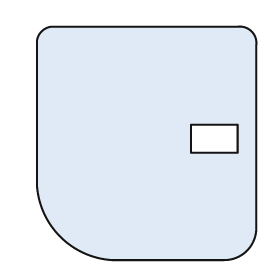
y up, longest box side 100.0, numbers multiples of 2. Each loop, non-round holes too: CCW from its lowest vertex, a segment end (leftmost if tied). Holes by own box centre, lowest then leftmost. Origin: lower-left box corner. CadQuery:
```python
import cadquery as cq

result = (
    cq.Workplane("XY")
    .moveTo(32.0, 0.0)
    .lineTo(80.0, 0.0)
    .threePointArc((90.0, 4.0), (94.0, 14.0))
    .lineTo(94.0, 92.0)
    .threePointArc((92.0, 98.0), (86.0, 100.0))
    .lineTo(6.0, 100.0)
    .threePointArc((2.0, 98.0), (0.0, 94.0))
    .lineTo(0.0, 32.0)
    .threePointArc((10.0, 10.0), (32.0, 0.0))
    .close()
    .moveTo(66.0, 46.0)
    .lineTo(86.0, 46.0)
    .lineTo(86.0, 58.0)
    .lineTo(66.0, 58.0)
    .close()
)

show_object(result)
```